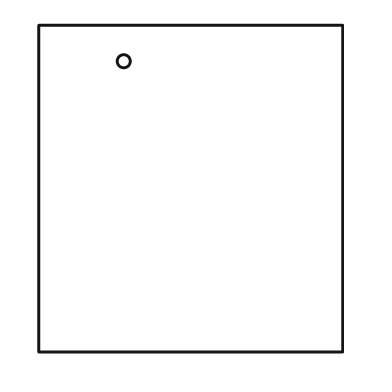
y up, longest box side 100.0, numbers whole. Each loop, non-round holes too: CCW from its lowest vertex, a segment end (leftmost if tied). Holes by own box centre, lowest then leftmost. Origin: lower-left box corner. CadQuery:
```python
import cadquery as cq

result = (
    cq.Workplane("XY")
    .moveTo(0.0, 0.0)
    .lineTo(93.0, 0.0)
    .lineTo(93.0, 100.0)
    .lineTo(0.0, 100.0)
    .close()
    .moveTo(26.0, 89.0)
    .circle(2.0)
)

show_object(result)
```